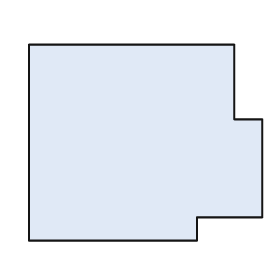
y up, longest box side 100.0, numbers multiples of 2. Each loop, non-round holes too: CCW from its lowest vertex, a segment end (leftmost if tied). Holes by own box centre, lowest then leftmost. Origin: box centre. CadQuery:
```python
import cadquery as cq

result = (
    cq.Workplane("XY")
    .moveTo(-50.0, -42.0)
    .lineTo(22.0, -42.0)
    .lineTo(22.0, -32.0)
    .lineTo(50.0, -32.0)
    .lineTo(50.0, 10.0)
    .lineTo(38.0, 10.0)
    .lineTo(38.0, 42.0)
    .lineTo(-50.0, 42.0)
    .close()
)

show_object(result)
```